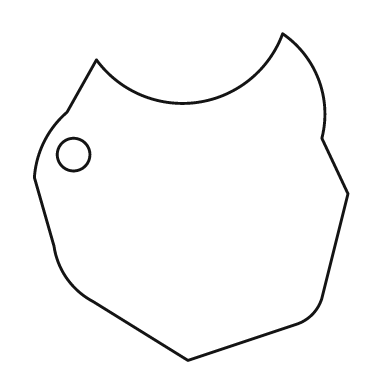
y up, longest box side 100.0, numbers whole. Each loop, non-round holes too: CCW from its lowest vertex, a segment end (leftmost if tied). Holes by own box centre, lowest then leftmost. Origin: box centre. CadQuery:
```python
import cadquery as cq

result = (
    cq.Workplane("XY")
    .moveTo(-1.0, -50.0)
    .lineTo(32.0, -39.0)
    .threePointArc((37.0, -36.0), (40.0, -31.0))
    .lineTo(48.0, 1.0)
    .lineTo(40.0, 18.0)
    .threePointArc((39.0, 36.0), (28.0, 50.0))
    .threePointArc((2.0, 29.0), (-29.0, 42.0))
    .lineTo(-38.0, 26.0)
    .threePointArc((-45.0, 17.0), (-48.0, 6.0))
    .lineTo(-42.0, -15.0)
    .threePointArc((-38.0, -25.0), (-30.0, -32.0))
    .close()
    .moveTo(-36.0, 13.0)
    .circle(5.0)
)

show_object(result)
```